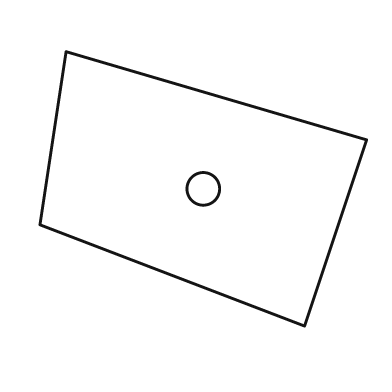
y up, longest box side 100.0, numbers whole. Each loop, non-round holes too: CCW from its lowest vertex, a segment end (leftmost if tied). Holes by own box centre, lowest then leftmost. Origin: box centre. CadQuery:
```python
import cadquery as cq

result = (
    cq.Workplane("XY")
    .moveTo(31.0, -42.0)
    .lineTo(50.0, 15.0)
    .lineTo(-42.0, 42.0)
    .lineTo(-50.0, -11.0)
    .close()
    .moveTo(0.0, 0.0)
    .circle(5.0)
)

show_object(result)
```